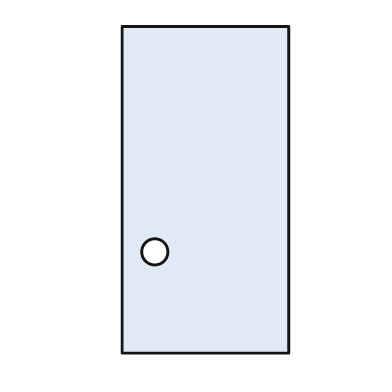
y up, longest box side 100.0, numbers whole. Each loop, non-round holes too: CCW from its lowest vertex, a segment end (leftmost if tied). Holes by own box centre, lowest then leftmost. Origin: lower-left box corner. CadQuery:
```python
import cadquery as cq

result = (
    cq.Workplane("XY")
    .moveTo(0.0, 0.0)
    .lineTo(51.0, 0.0)
    .lineTo(51.0, 100.0)
    .lineTo(0.0, 100.0)
    .close()
    .moveTo(10.0, 31.0)
    .circle(4.0)
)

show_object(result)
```